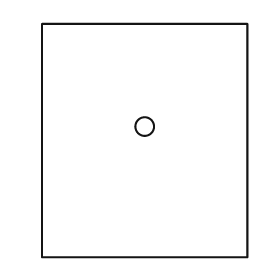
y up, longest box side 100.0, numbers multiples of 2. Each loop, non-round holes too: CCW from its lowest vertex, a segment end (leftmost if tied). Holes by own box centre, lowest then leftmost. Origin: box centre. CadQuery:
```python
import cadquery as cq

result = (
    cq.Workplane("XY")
    .moveTo(-44.0, -50.0)
    .lineTo(44.0, -50.0)
    .lineTo(44.0, 50.0)
    .lineTo(-44.0, 50.0)
    .close()
    .moveTo(0.0, 6.0)
    .circle(4.0)
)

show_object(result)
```